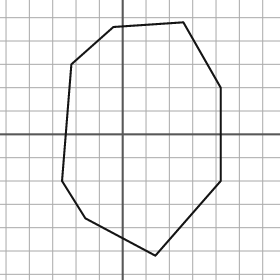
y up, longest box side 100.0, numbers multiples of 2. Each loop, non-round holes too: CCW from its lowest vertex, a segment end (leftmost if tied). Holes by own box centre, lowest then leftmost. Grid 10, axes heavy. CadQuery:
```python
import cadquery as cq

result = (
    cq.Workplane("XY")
    .moveTo(14.0, -52.0)
    .lineTo(42.0, -20.0)
    .lineTo(42.0, 20.0)
    .lineTo(26.0, 48.0)
    .lineTo(-4.0, 46.0)
    .lineTo(-22.0, 30.0)
    .lineTo(-26.0, -20.0)
    .lineTo(-16.0, -36.0)
    .close()
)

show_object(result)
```